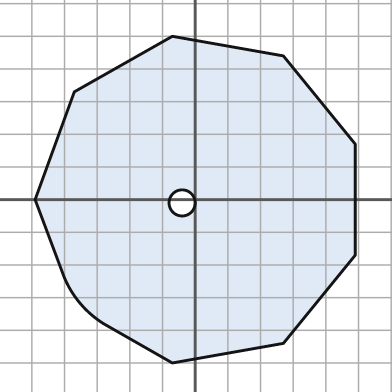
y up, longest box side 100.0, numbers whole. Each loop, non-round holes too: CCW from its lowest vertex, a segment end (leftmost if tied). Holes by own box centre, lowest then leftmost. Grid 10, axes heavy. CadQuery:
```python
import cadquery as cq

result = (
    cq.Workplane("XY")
    .moveTo(-7.0, -50.0)
    .lineTo(27.0, -44.0)
    .lineTo(49.0, -17.0)
    .lineTo(49.0, 17.0)
    .lineTo(27.0, 44.0)
    .lineTo(-7.0, 50.0)
    .lineTo(-37.0, 33.0)
    .lineTo(-49.0, 0.0)
    .lineTo(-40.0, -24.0)
    .threePointArc((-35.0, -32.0), (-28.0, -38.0))
    .close()
    .moveTo(-4.0, -1.0)
    .circle(4.0)
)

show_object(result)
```